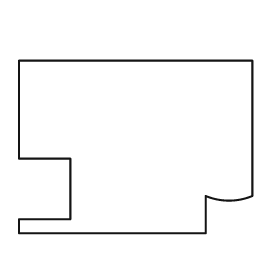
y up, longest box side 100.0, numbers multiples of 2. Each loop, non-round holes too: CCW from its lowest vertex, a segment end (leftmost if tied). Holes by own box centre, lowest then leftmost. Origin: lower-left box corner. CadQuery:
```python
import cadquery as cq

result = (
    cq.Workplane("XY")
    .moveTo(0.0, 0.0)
    .lineTo(80.0, 0.0)
    .lineTo(80.0, 16.0)
    .threePointArc((90.0, 14.0), (100.0, 16.0))
    .lineTo(100.0, 74.0)
    .lineTo(0.0, 74.0)
    .lineTo(0.0, 32.0)
    .lineTo(22.0, 32.0)
    .lineTo(22.0, 6.0)
    .lineTo(0.0, 6.0)
    .close()
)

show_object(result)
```